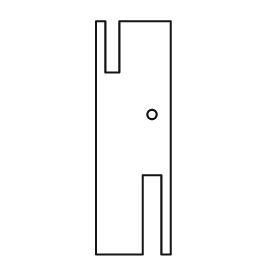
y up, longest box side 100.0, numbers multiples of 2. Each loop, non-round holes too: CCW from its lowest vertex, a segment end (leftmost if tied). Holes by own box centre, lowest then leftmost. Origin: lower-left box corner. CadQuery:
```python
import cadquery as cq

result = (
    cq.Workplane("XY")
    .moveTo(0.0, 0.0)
    .lineTo(20.0, 0.0)
    .lineTo(20.0, 34.0)
    .lineTo(28.0, 34.0)
    .lineTo(28.0, 0.0)
    .lineTo(32.0, 0.0)
    .lineTo(32.0, 100.0)
    .lineTo(10.0, 100.0)
    .lineTo(10.0, 78.0)
    .lineTo(4.0, 78.0)
    .lineTo(4.0, 100.0)
    .lineTo(0.0, 100.0)
    .close()
    .moveTo(24.0, 60.0)
    .circle(2.0)
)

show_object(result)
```